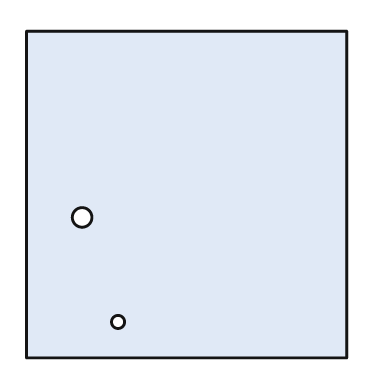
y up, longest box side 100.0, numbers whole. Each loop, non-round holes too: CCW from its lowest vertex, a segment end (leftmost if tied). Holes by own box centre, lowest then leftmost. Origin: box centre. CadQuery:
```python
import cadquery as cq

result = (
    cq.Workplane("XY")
    .moveTo(-49.0, -50.0)
    .lineTo(49.0, -50.0)
    .lineTo(49.0, 50.0)
    .lineTo(-49.0, 50.0)
    .close()
    .moveTo(-21.0, -39.0)
    .circle(2.0)
    .moveTo(-32.0, -7.0)
    .circle(3.0)
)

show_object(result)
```